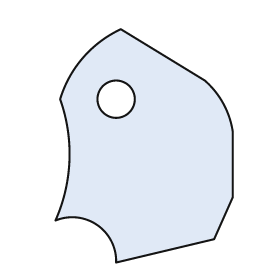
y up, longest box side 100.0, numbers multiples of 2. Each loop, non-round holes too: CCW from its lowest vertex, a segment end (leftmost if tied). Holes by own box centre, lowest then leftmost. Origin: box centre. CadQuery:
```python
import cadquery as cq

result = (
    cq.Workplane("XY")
    .moveTo(-12.0, -50.0)
    .lineTo(30.0, -40.0)
    .lineTo(38.0, -22.0)
    .lineTo(38.0, 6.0)
    .threePointArc((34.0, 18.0), (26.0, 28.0))
    .lineTo(-10.0, 50.0)
    .threePointArc((-26.0, 38.0), (-36.0, 20.0))
    .threePointArc((-32.0, -6.0), (-38.0, -32.0))
    .threePointArc((-20.0, -34.0), (-12.0, -50.0))
    .close()
    .moveTo(-12.0, 20.0)
    .circle(8.0)
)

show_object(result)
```